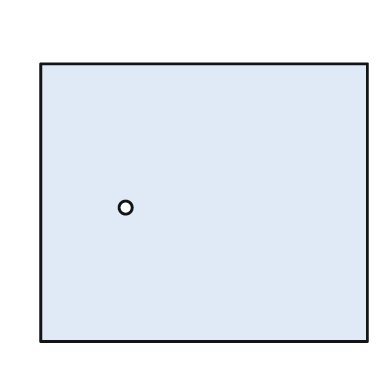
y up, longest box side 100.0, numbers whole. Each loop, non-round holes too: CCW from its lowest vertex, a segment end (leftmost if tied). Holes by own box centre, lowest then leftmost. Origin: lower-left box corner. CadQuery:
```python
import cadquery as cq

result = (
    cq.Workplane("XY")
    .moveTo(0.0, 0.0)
    .lineTo(100.0, 0.0)
    .lineTo(100.0, 85.0)
    .lineTo(0.0, 85.0)
    .close()
    .moveTo(26.0, 41.0)
    .circle(2.0)
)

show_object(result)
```